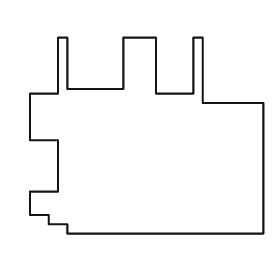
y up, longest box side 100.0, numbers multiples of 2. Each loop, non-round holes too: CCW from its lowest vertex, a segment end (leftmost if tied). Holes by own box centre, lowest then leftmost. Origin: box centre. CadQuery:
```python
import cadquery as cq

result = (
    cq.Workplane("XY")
    .moveTo(-34.0, -42.0)
    .lineTo(50.0, -42.0)
    .lineTo(50.0, 14.0)
    .lineTo(24.0, 14.0)
    .lineTo(24.0, 42.0)
    .lineTo(20.0, 42.0)
    .lineTo(20.0, 18.0)
    .lineTo(4.0, 18.0)
    .lineTo(4.0, 42.0)
    .lineTo(-10.0, 42.0)
    .lineTo(-10.0, 20.0)
    .lineTo(-34.0, 20.0)
    .lineTo(-34.0, 42.0)
    .lineTo(-38.0, 42.0)
    .lineTo(-38.0, 18.0)
    .lineTo(-50.0, 18.0)
    .lineTo(-50.0, -2.0)
    .lineTo(-38.0, -2.0)
    .lineTo(-38.0, -24.0)
    .lineTo(-50.0, -24.0)
    .lineTo(-50.0, -34.0)
    .lineTo(-42.0, -34.0)
    .lineTo(-42.0, -38.0)
    .lineTo(-34.0, -38.0)
    .close()
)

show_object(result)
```